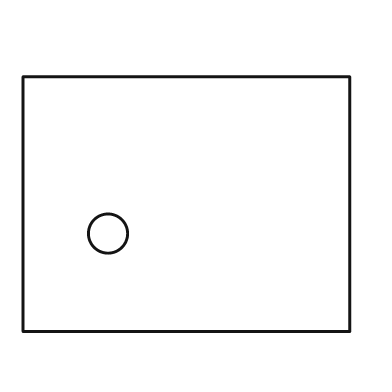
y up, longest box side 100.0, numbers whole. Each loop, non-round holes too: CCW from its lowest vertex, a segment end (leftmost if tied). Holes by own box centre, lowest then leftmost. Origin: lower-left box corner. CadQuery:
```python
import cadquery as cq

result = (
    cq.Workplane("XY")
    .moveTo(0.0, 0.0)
    .lineTo(100.0, 0.0)
    .lineTo(100.0, 78.0)
    .lineTo(0.0, 78.0)
    .close()
    .moveTo(26.0, 30.0)
    .circle(6.0)
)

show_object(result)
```